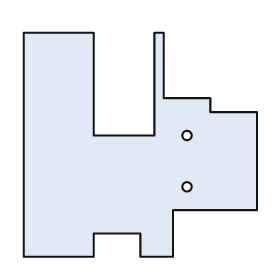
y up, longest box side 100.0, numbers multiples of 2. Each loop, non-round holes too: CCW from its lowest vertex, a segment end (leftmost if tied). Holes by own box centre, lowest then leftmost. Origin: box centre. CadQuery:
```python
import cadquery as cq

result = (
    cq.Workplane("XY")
    .moveTo(-50.0, -48.0)
    .lineTo(-20.0, -48.0)
    .lineTo(-20.0, -38.0)
    .lineTo(0.0, -38.0)
    .lineTo(0.0, -48.0)
    .lineTo(14.0, -48.0)
    .lineTo(14.0, -28.0)
    .lineTo(50.0, -28.0)
    .lineTo(50.0, 14.0)
    .lineTo(30.0, 14.0)
    .lineTo(30.0, 20.0)
    .lineTo(10.0, 20.0)
    .lineTo(10.0, 48.0)
    .lineTo(6.0, 48.0)
    .lineTo(6.0, 4.0)
    .lineTo(-20.0, 4.0)
    .lineTo(-20.0, 48.0)
    .lineTo(-50.0, 48.0)
    .close()
    .moveTo(20.0, -18.0)
    .circle(2.0)
    .moveTo(20.0, 4.0)
    .circle(2.0)
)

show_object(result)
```